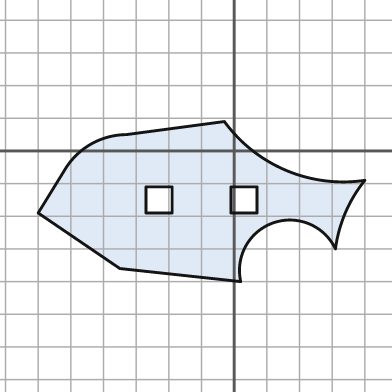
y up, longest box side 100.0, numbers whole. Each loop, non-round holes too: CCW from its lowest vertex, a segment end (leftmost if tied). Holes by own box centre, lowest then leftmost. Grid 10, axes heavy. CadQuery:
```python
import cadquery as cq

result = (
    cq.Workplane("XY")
    .moveTo(2.0, -40.0)
    .threePointArc((12.0, -22.0), (31.0, -30.0))
    .threePointArc((34.0, -19.0), (40.0, -9.0))
    .threePointArc((16.0, -6.0), (-3.0, 9.0))
    .lineTo(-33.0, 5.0)
    .threePointArc((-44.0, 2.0), (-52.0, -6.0))
    .lineTo(-60.0, -19.0)
    .lineTo(-35.0, -36.0)
    .close()
    .moveTo(-27.0, -19.0)
    .lineTo(-19.0, -19.0)
    .lineTo(-19.0, -11.0)
    .lineTo(-27.0, -11.0)
    .close()
    .moveTo(-1.0, -19.0)
    .lineTo(7.0, -19.0)
    .lineTo(7.0, -11.0)
    .lineTo(-1.0, -11.0)
    .close()
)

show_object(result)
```